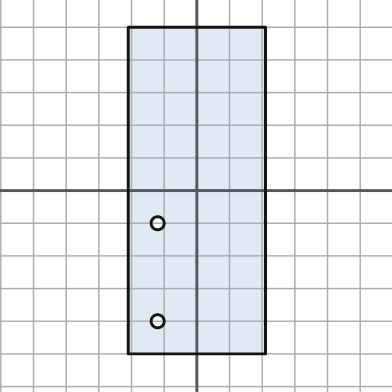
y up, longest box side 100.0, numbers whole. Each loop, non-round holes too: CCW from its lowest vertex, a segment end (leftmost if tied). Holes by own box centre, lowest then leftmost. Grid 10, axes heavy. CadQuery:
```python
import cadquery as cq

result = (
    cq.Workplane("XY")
    .moveTo(-21.0, -50.0)
    .lineTo(21.0, -50.0)
    .lineTo(21.0, 50.0)
    .lineTo(-21.0, 50.0)
    .close()
    .moveTo(-12.0, -40.0)
    .circle(2.0)
    .moveTo(-12.0, -10.0)
    .circle(2.0)
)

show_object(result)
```